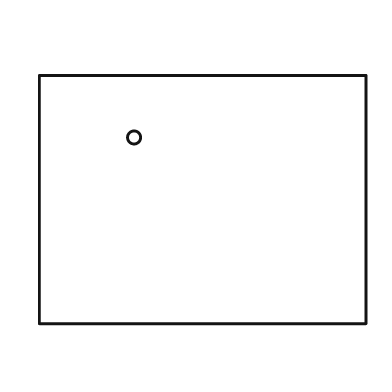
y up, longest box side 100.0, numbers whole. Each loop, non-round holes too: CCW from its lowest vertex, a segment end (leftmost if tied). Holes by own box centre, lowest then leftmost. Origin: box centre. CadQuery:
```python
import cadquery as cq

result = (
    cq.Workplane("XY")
    .moveTo(-50.0, -38.0)
    .lineTo(50.0, -38.0)
    .lineTo(50.0, 38.0)
    .lineTo(-50.0, 38.0)
    .close()
    .moveTo(-21.0, 19.0)
    .circle(2.0)
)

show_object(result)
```